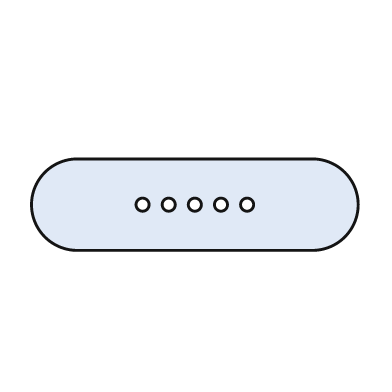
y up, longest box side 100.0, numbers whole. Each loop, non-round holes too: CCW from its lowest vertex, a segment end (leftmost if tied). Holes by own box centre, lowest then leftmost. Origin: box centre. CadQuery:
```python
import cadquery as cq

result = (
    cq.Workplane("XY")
    .moveTo(-36.0, -14.0)
    .lineTo(36.0, -14.0)
    .threePointArc((50.0, 0.0), (36.0, 14.0))
    .lineTo(-36.0, 14.0)
    .threePointArc((-50.0, 0.0), (-36.0, -14.0))
    .close()
    .moveTo(-16.0, 0.0)
    .circle(2.0)
    .moveTo(-8.0, 0.0)
    .circle(2.0)
    .moveTo(0.0, 0.0)
    .circle(2.0)
    .moveTo(8.0, 0.0)
    .circle(2.0)
    .moveTo(16.0, 0.0)
    .circle(2.0)
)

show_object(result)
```